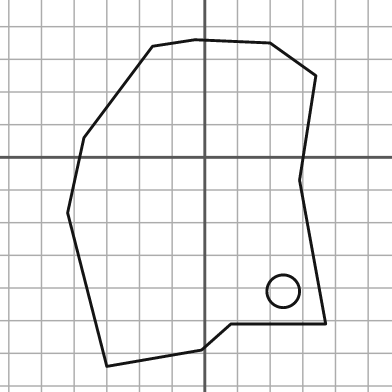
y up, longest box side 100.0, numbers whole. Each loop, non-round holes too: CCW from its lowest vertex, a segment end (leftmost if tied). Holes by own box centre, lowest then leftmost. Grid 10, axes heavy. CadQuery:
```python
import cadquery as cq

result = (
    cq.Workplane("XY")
    .moveTo(-30.0, -64.0)
    .lineTo(-1.0, -59.0)
    .lineTo(8.0, -51.0)
    .lineTo(37.0, -51.0)
    .lineTo(29.0, -7.0)
    .lineTo(34.0, 25.0)
    .lineTo(20.0, 35.0)
    .lineTo(-3.0, 36.0)
    .lineTo(-16.0, 34.0)
    .lineTo(-37.0, 6.0)
    .lineTo(-42.0, -17.0)
    .close()
    .moveTo(24.0, -41.0)
    .circle(5.0)
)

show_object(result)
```